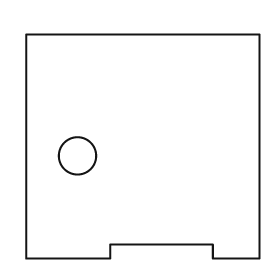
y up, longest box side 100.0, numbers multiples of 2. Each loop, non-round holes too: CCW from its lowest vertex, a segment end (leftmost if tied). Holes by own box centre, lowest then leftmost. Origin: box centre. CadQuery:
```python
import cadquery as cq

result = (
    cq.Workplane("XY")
    .moveTo(-50.0, -48.0)
    .lineTo(-14.0, -48.0)
    .lineTo(-14.0, -42.0)
    .lineTo(30.0, -42.0)
    .lineTo(30.0, -48.0)
    .lineTo(50.0, -48.0)
    .lineTo(50.0, 48.0)
    .lineTo(-50.0, 48.0)
    .close()
    .moveTo(-28.0, -4.0)
    .circle(8.0)
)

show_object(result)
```